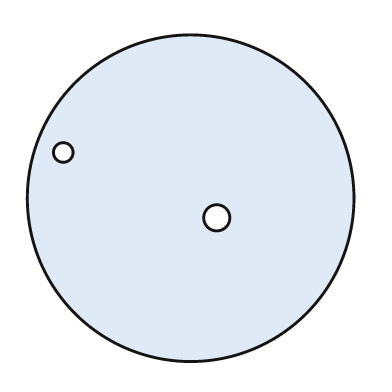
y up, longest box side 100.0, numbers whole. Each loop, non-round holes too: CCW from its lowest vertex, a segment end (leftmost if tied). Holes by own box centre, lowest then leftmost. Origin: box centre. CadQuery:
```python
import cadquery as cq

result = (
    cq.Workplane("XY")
    .moveTo(0.0, 0.0)
    .circle(50.0)
    .moveTo(8.0, -6.0)
    .circle(4.0)
    .moveTo(-39.0, 14.0)
    .circle(3.0)
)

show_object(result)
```